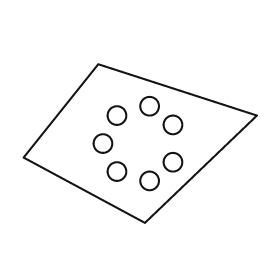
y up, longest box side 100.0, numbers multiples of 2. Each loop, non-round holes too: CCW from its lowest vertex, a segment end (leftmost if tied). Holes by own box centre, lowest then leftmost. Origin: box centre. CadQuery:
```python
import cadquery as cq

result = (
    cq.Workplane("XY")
    .moveTo(2.0, -34.0)
    .lineTo(50.0, 12.0)
    .lineTo(-18.0, 34.0)
    .lineTo(-50.0, -6.0)
    .close()
    .moveTo(4.0, -16.0)
    .circle(4.0)
    .moveTo(-10.0, -12.0)
    .circle(4.0)
    .moveTo(14.0, -8.0)
    .circle(4.0)
    .moveTo(-16.0, 0.0)
    .circle(4.0)
    .moveTo(14.0, 8.0)
    .circle(4.0)
    .moveTo(-10.0, 12.0)
    .circle(4.0)
    .moveTo(4.0, 16.0)
    .circle(4.0)
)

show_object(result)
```